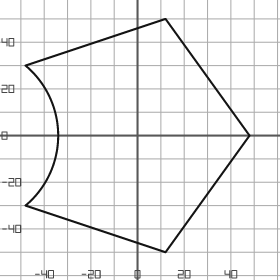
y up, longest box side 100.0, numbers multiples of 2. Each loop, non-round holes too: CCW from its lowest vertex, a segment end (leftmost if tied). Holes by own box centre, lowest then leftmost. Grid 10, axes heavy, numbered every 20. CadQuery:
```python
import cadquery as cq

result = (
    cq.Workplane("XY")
    .moveTo(12.0, -50.0)
    .lineTo(48.0, 0.0)
    .lineTo(12.0, 50.0)
    .lineTo(-48.0, 30.0)
    .threePointArc((-34.0, 0.0), (-48.0, -30.0))
    .close()
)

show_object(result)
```